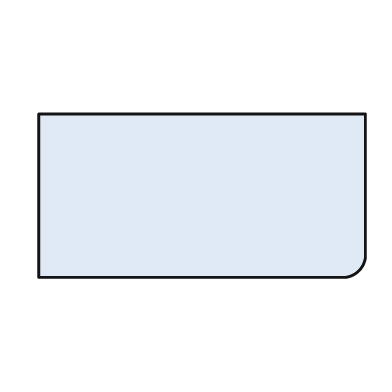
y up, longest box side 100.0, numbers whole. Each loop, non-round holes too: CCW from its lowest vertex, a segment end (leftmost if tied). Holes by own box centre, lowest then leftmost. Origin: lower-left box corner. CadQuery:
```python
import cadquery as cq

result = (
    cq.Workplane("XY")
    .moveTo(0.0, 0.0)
    .lineTo(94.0, 0.0)
    .threePointArc((98.0, 2.0), (100.0, 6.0))
    .lineTo(100.0, 50.0)
    .lineTo(0.0, 50.0)
    .close()
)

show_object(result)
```